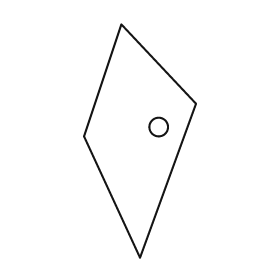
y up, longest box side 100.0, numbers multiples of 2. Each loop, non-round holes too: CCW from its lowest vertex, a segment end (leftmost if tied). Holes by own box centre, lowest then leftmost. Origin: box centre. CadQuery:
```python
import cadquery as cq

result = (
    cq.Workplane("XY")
    .moveTo(0.0, -50.0)
    .lineTo(24.0, 16.0)
    .lineTo(-8.0, 50.0)
    .lineTo(-24.0, 2.0)
    .close()
    .moveTo(8.0, 6.0)
    .circle(4.0)
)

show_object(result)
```